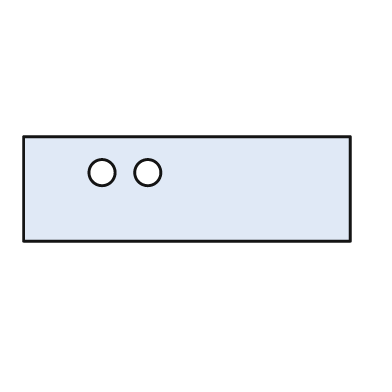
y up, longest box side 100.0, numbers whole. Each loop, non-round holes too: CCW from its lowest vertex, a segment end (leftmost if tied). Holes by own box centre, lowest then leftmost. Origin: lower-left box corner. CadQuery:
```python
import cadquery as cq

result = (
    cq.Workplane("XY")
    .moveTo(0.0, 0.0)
    .lineTo(100.0, 0.0)
    .lineTo(100.0, 32.0)
    .lineTo(0.0, 32.0)
    .close()
    .moveTo(24.0, 21.0)
    .circle(4.0)
    .moveTo(38.0, 21.0)
    .circle(4.0)
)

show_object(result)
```